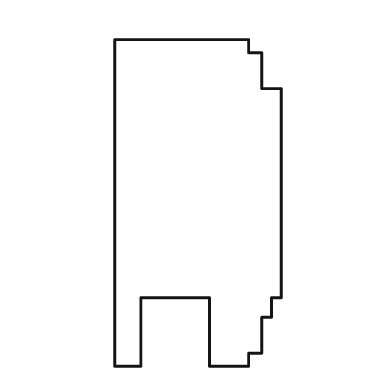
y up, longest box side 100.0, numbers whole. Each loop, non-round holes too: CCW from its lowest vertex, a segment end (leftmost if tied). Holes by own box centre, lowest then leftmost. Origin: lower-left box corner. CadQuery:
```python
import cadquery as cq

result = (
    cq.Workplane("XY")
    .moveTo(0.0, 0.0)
    .lineTo(8.0, 0.0)
    .lineTo(8.0, 21.0)
    .lineTo(29.0, 21.0)
    .lineTo(29.0, 0.0)
    .lineTo(41.0, 0.0)
    .lineTo(41.0, 4.0)
    .lineTo(45.0, 4.0)
    .lineTo(45.0, 15.0)
    .lineTo(48.0, 15.0)
    .lineTo(48.0, 21.0)
    .lineTo(51.0, 21.0)
    .lineTo(51.0, 85.0)
    .lineTo(45.0, 85.0)
    .lineTo(45.0, 96.0)
    .lineTo(41.0, 96.0)
    .lineTo(41.0, 100.0)
    .lineTo(0.0, 100.0)
    .close()
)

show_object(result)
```